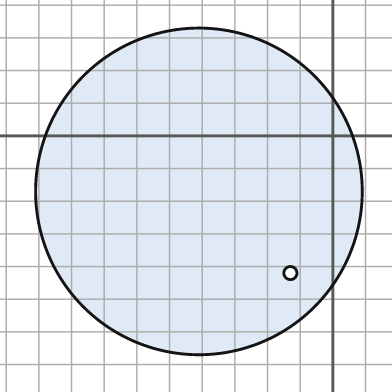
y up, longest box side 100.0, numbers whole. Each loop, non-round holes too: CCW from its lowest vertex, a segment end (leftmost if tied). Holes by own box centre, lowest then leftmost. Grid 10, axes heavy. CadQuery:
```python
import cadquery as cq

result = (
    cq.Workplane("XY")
    .moveTo(-41.0, -17.0)
    .circle(50.0)
    .moveTo(-13.0, -42.0)
    .circle(2.0)
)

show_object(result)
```